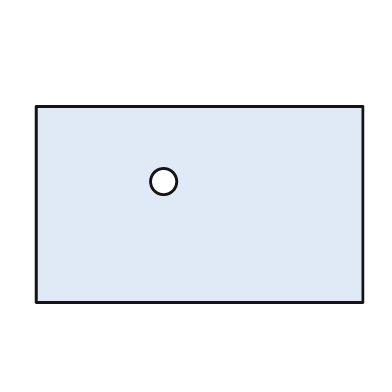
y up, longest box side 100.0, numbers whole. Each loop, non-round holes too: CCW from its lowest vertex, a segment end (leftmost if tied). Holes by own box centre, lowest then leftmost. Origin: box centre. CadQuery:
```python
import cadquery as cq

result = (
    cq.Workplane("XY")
    .moveTo(-50.0, -30.0)
    .lineTo(50.0, -30.0)
    .lineTo(50.0, 30.0)
    .lineTo(-50.0, 30.0)
    .close()
    .moveTo(-11.0, 7.0)
    .circle(4.0)
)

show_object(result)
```